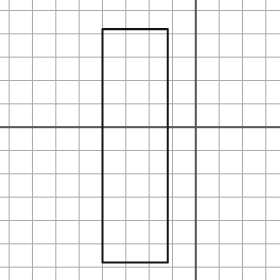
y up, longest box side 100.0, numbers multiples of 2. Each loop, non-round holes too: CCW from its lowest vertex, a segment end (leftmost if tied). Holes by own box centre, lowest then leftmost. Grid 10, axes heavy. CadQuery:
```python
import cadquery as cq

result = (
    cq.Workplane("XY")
    .moveTo(-40.0, -58.0)
    .lineTo(-12.0, -58.0)
    .lineTo(-12.0, 42.0)
    .lineTo(-40.0, 42.0)
    .close()
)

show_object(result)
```